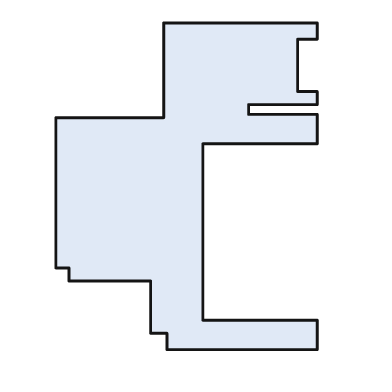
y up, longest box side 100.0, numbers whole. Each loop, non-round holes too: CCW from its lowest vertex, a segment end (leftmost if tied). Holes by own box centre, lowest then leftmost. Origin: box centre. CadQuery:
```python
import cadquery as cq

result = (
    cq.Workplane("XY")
    .moveTo(-6.0, -50.0)
    .lineTo(40.0, -50.0)
    .lineTo(40.0, -41.0)
    .lineTo(5.0, -41.0)
    .lineTo(5.0, 13.0)
    .lineTo(40.0, 13.0)
    .lineTo(40.0, 22.0)
    .lineTo(19.0, 22.0)
    .lineTo(19.0, 25.0)
    .lineTo(40.0, 25.0)
    .lineTo(40.0, 29.0)
    .lineTo(34.0, 29.0)
    .lineTo(34.0, 45.0)
    .lineTo(40.0, 45.0)
    .lineTo(40.0, 50.0)
    .lineTo(-7.0, 50.0)
    .lineTo(-7.0, 21.0)
    .lineTo(-40.0, 21.0)
    .lineTo(-40.0, -25.0)
    .lineTo(-36.0, -25.0)
    .lineTo(-36.0, -29.0)
    .lineTo(-11.0, -29.0)
    .lineTo(-11.0, -45.0)
    .lineTo(-6.0, -45.0)
    .close()
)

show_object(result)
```